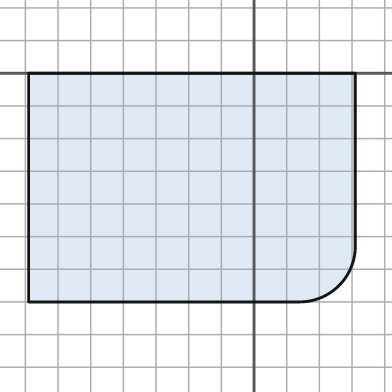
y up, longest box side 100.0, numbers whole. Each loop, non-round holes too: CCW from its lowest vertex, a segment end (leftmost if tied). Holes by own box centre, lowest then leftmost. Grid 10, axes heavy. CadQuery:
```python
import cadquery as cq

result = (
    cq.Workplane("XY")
    .moveTo(-69.0, -70.0)
    .lineTo(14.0, -70.0)
    .threePointArc((26.0, -65.0), (31.0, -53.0))
    .lineTo(31.0, 0.0)
    .lineTo(-69.0, 0.0)
    .close()
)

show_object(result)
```